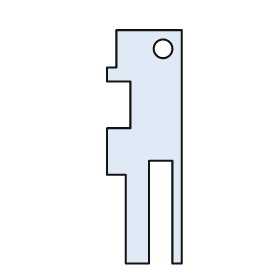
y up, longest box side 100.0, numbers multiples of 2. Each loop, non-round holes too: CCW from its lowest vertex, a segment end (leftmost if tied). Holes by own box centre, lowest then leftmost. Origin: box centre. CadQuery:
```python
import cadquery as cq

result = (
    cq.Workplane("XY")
    .moveTo(-8.0, -50.0)
    .lineTo(2.0, -50.0)
    .lineTo(2.0, -6.0)
    .lineTo(12.0, -6.0)
    .lineTo(12.0, -50.0)
    .lineTo(16.0, -50.0)
    .lineTo(16.0, 50.0)
    .lineTo(-12.0, 50.0)
    .lineTo(-12.0, 34.0)
    .lineTo(-16.0, 34.0)
    .lineTo(-16.0, 28.0)
    .lineTo(-6.0, 28.0)
    .lineTo(-6.0, 8.0)
    .lineTo(-16.0, 8.0)
    .lineTo(-16.0, -12.0)
    .lineTo(-8.0, -12.0)
    .close()
    .moveTo(8.0, 42.0)
    .circle(4.0)
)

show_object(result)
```